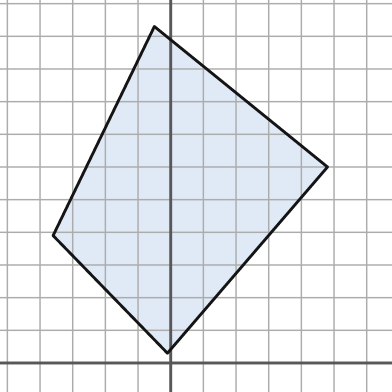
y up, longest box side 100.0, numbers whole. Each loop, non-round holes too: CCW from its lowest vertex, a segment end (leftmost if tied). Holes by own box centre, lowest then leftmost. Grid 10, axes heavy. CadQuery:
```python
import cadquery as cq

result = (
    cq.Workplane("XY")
    .moveTo(-1.0, 3.0)
    .lineTo(48.0, 60.0)
    .lineTo(-5.0, 103.0)
    .lineTo(-36.0, 39.0)
    .close()
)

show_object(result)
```